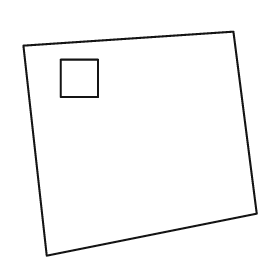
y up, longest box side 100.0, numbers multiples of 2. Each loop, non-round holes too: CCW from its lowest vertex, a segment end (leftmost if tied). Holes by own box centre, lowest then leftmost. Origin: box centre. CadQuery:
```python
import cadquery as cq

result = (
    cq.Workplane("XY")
    .moveTo(-40.0, -48.0)
    .lineTo(50.0, -30.0)
    .lineTo(40.0, 48.0)
    .lineTo(-50.0, 42.0)
    .close()
    .moveTo(-34.0, 20.0)
    .lineTo(-18.0, 20.0)
    .lineTo(-18.0, 36.0)
    .lineTo(-34.0, 36.0)
    .close()
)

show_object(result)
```